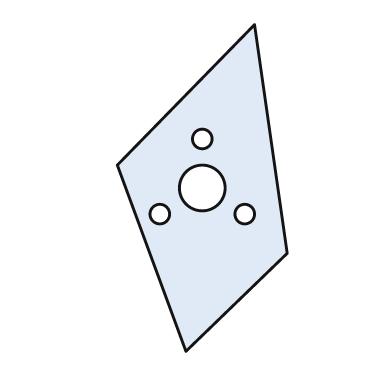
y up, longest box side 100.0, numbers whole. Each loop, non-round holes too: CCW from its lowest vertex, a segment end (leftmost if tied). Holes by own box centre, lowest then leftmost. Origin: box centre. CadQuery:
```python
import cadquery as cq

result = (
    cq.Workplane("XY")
    .moveTo(-5.0, -50.0)
    .lineTo(26.0, -20.0)
    .lineTo(16.0, 50.0)
    .lineTo(-26.0, 7.0)
    .close()
    .moveTo(-13.0, -8.0)
    .circle(3.0)
    .moveTo(13.0, -8.0)
    .circle(3.0)
    .moveTo(0.0, 0.0)
    .circle(7.0)
    .moveTo(0.0, 15.0)
    .circle(3.0)
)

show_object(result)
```